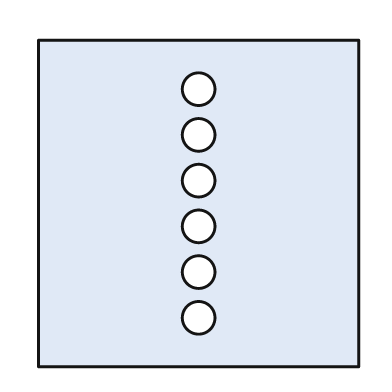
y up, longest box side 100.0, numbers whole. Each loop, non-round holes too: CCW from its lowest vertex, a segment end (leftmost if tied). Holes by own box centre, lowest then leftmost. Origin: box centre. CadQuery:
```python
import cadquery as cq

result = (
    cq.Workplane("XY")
    .moveTo(-49.0, -50.0)
    .lineTo(49.0, -50.0)
    .lineTo(49.0, 50.0)
    .lineTo(-49.0, 50.0)
    .close()
    .moveTo(0.0, -35.0)
    .circle(5.0)
    .moveTo(0.0, -21.0)
    .circle(5.0)
    .moveTo(0.0, -7.0)
    .circle(5.0)
    .moveTo(0.0, 7.0)
    .circle(5.0)
    .moveTo(0.0, 21.0)
    .circle(5.0)
    .moveTo(0.0, 35.0)
    .circle(5.0)
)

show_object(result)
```